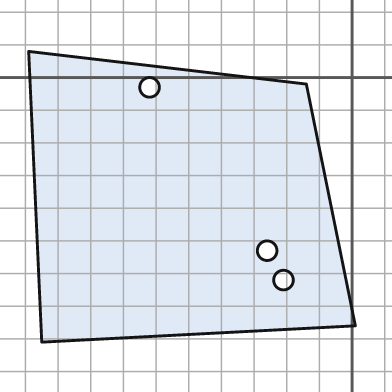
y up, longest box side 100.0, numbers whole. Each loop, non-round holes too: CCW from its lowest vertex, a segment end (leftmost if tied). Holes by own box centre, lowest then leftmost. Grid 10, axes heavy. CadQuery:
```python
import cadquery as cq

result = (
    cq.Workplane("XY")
    .moveTo(-95.0, -81.0)
    .lineTo(1.0, -76.0)
    .lineTo(-14.0, -2.0)
    .lineTo(-99.0, 8.0)
    .close()
    .moveTo(-21.0, -62.0)
    .circle(3.0)
    .moveTo(-26.0, -53.0)
    .circle(3.0)
    .moveTo(-62.0, -3.0)
    .circle(3.0)
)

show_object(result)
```